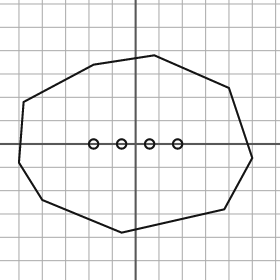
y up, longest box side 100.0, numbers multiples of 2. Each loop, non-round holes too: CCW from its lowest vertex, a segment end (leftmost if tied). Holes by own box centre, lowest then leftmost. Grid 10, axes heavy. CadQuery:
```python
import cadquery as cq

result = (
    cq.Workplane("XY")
    .moveTo(-6.0, -38.0)
    .lineTo(38.0, -28.0)
    .lineTo(50.0, -6.0)
    .lineTo(40.0, 24.0)
    .lineTo(8.0, 38.0)
    .lineTo(-18.0, 34.0)
    .lineTo(-48.0, 18.0)
    .lineTo(-50.0, -8.0)
    .lineTo(-40.0, -24.0)
    .close()
    .moveTo(-18.0, 0.0)
    .circle(2.0)
    .moveTo(-6.0, 0.0)
    .circle(2.0)
    .moveTo(6.0, 0.0)
    .circle(2.0)
    .moveTo(18.0, 0.0)
    .circle(2.0)
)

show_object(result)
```